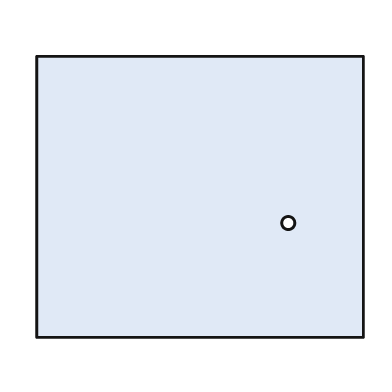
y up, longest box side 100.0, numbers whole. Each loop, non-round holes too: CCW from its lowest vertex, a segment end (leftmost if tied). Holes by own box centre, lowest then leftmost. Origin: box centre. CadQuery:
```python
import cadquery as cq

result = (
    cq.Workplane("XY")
    .moveTo(-50.0, -43.0)
    .lineTo(50.0, -43.0)
    .lineTo(50.0, 43.0)
    .lineTo(-50.0, 43.0)
    .close()
    .moveTo(27.0, -8.0)
    .circle(2.0)
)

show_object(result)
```